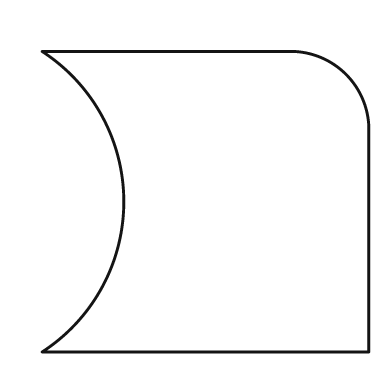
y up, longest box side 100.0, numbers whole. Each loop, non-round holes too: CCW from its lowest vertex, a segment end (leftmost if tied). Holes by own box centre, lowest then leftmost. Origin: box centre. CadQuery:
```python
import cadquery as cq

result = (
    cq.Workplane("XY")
    .moveTo(-50.0, -46.0)
    .lineTo(50.0, -46.0)
    .lineTo(50.0, 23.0)
    .threePointArc((43.0, 39.0), (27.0, 46.0))
    .lineTo(-50.0, 46.0)
    .threePointArc((-25.0, 0.0), (-50.0, -46.0))
    .close()
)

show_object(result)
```